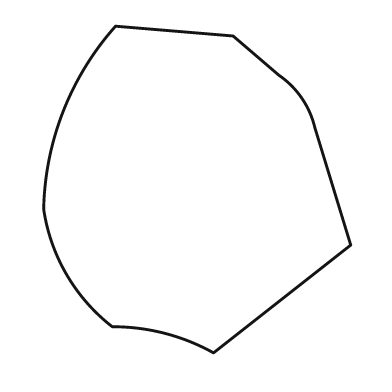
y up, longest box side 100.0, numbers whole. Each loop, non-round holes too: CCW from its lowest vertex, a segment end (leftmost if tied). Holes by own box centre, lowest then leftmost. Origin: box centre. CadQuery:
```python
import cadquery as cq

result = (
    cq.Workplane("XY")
    .moveTo(5.0, -50.0)
    .lineTo(47.0, -17.0)
    .lineTo(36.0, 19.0)
    .threePointArc((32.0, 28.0), (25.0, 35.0))
    .lineTo(11.0, 47.0)
    .lineTo(-25.0, 50.0)
    .threePointArc((-41.0, 24.0), (-47.0, -6.0))
    .threePointArc((-40.0, -26.0), (-26.0, -42.0))
    .threePointArc((-10.0, -44.0), (5.0, -50.0))
    .close()
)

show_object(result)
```